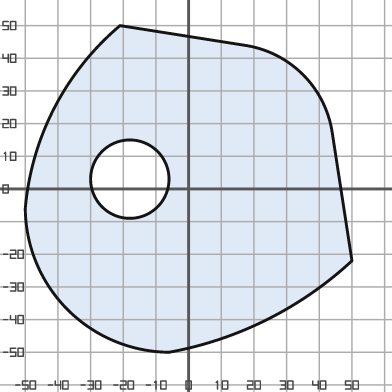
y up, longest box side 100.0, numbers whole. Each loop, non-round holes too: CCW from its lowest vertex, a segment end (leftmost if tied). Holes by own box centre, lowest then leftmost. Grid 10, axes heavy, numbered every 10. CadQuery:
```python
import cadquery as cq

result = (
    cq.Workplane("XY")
    .moveTo(-6.0, -50.0)
    .threePointArc((24.0, -40.0), (50.0, -22.0))
    .lineTo(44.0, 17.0)
    .threePointArc((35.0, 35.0), (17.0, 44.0))
    .lineTo(-21.0, 50.0)
    .threePointArc((-41.0, 25.0), (-50.0, -6.0))
    .threePointArc((-37.0, -37.0), (-6.0, -50.0))
    .close()
    .moveTo(-18.0, 3.0)
    .circle(12.0)
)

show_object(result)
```